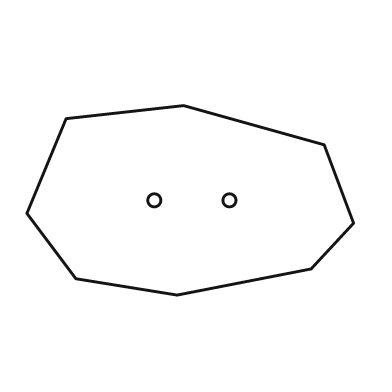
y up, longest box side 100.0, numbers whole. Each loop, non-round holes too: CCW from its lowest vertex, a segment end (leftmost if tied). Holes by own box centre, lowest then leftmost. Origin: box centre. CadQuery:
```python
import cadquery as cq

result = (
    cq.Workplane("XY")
    .moveTo(-4.0, -29.0)
    .lineTo(37.0, -21.0)
    .lineTo(50.0, -7.0)
    .lineTo(41.0, 17.0)
    .lineTo(-2.0, 29.0)
    .lineTo(-38.0, 25.0)
    .lineTo(-50.0, -4.0)
    .lineTo(-35.0, -24.0)
    .close()
    .moveTo(-11.0, 0.0)
    .circle(2.0)
    .moveTo(12.0, 0.0)
    .circle(2.0)
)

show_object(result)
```